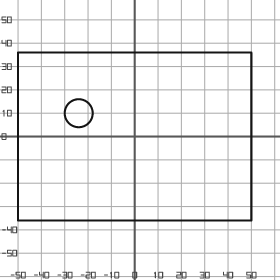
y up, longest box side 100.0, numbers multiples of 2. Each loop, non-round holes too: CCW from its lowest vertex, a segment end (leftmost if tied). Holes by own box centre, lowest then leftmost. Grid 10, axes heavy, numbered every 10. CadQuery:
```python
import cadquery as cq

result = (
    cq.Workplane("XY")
    .moveTo(-50.0, -36.0)
    .lineTo(50.0, -36.0)
    .lineTo(50.0, 36.0)
    .lineTo(-50.0, 36.0)
    .close()
    .moveTo(-24.0, 10.0)
    .circle(6.0)
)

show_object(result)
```